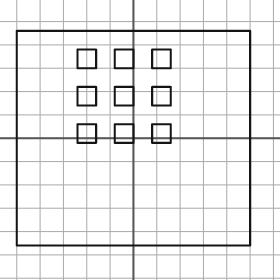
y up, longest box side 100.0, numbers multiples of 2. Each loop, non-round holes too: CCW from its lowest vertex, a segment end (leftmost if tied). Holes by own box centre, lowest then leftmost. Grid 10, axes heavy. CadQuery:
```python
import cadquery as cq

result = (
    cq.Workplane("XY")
    .moveTo(-50.0, -46.0)
    .lineTo(50.0, -46.0)
    .lineTo(50.0, 46.0)
    .lineTo(-50.0, 46.0)
    .close()
    .moveTo(-24.0, -2.0)
    .lineTo(-16.0, -2.0)
    .lineTo(-16.0, 6.0)
    .lineTo(-24.0, 6.0)
    .close()
    .moveTo(-8.0, -2.0)
    .lineTo(0.0, -2.0)
    .lineTo(0.0, 6.0)
    .lineTo(-8.0, 6.0)
    .close()
    .moveTo(8.0, -2.0)
    .lineTo(16.0, -2.0)
    .lineTo(16.0, 6.0)
    .lineTo(8.0, 6.0)
    .close()
    .moveTo(-24.0, 14.0)
    .lineTo(-16.0, 14.0)
    .lineTo(-16.0, 22.0)
    .lineTo(-24.0, 22.0)
    .close()
    .moveTo(-8.0, 14.0)
    .lineTo(0.0, 14.0)
    .lineTo(0.0, 22.0)
    .lineTo(-8.0, 22.0)
    .close()
    .moveTo(8.0, 14.0)
    .lineTo(16.0, 14.0)
    .lineTo(16.0, 22.0)
    .lineTo(8.0, 22.0)
    .close()
    .moveTo(-24.0, 30.0)
    .lineTo(-16.0, 30.0)
    .lineTo(-16.0, 38.0)
    .lineTo(-24.0, 38.0)
    .close()
    .moveTo(-8.0, 30.0)
    .lineTo(0.0, 30.0)
    .lineTo(0.0, 38.0)
    .lineTo(-8.0, 38.0)
    .close()
    .moveTo(8.0, 30.0)
    .lineTo(16.0, 30.0)
    .lineTo(16.0, 38.0)
    .lineTo(8.0, 38.0)
    .close()
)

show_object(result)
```